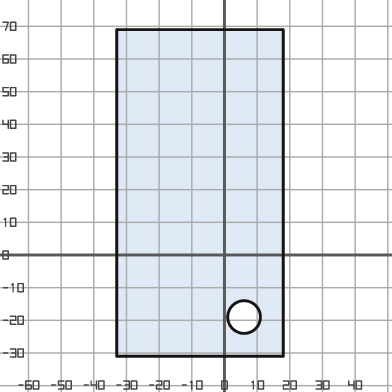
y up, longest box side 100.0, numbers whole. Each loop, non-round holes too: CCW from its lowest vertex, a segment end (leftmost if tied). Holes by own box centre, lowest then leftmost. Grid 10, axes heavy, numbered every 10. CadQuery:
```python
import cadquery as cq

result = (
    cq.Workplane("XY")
    .moveTo(-33.0, -31.0)
    .lineTo(18.0, -31.0)
    .lineTo(18.0, 69.0)
    .lineTo(-33.0, 69.0)
    .close()
    .moveTo(6.0, -19.0)
    .circle(5.0)
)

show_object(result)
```